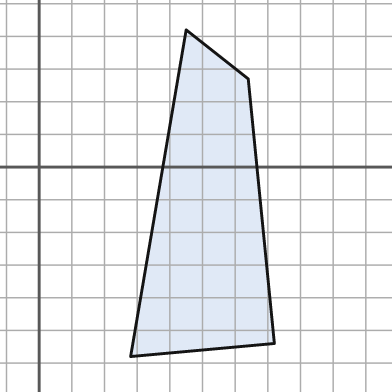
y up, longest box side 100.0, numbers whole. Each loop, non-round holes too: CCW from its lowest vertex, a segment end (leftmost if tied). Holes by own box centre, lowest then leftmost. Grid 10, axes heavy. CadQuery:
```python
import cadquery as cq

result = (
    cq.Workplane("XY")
    .moveTo(28.0, -58.0)
    .lineTo(72.0, -54.0)
    .lineTo(64.0, 27.0)
    .lineTo(45.0, 42.0)
    .close()
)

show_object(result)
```